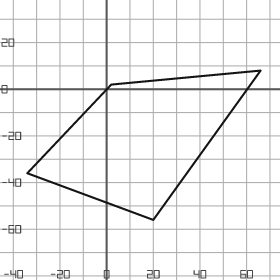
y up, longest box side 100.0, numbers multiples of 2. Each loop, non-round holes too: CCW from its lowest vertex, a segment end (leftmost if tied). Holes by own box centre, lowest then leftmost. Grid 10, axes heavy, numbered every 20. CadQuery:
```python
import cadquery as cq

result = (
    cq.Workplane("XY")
    .moveTo(20.0, -56.0)
    .lineTo(66.0, 8.0)
    .lineTo(2.0, 2.0)
    .lineTo(-34.0, -36.0)
    .close()
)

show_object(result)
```